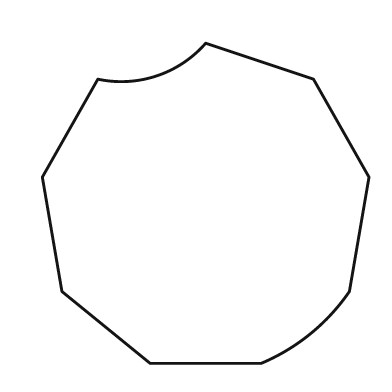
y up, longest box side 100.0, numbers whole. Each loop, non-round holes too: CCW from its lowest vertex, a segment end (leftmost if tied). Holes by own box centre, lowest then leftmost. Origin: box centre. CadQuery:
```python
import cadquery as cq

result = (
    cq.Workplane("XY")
    .moveTo(-17.0, -49.0)
    .lineTo(17.0, -49.0)
    .threePointArc((32.0, -40.0), (44.0, -27.0))
    .lineTo(50.0, 8.0)
    .lineTo(33.0, 38.0)
    .lineTo(0.0, 49.0)
    .threePointArc((-15.0, 39.0), (-33.0, 38.0))
    .lineTo(-50.0, 8.0)
    .lineTo(-44.0, -27.0)
    .close()
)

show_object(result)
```